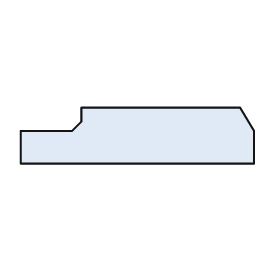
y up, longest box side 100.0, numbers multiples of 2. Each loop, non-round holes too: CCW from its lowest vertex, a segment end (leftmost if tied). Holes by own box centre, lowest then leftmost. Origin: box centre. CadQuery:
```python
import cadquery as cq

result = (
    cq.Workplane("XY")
    .moveTo(-50.0, -12.0)
    .lineTo(50.0, -12.0)
    .lineTo(50.0, 2.0)
    .lineTo(44.0, 12.0)
    .lineTo(-24.0, 12.0)
    .lineTo(-24.0, 6.0)
    .lineTo(-28.0, 2.0)
    .lineTo(-50.0, 2.0)
    .close()
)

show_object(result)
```